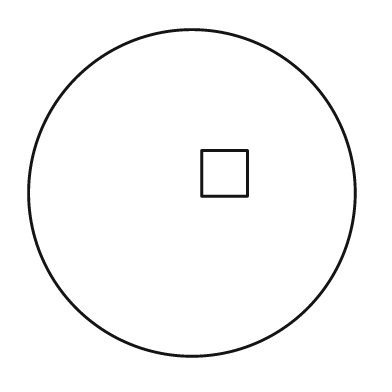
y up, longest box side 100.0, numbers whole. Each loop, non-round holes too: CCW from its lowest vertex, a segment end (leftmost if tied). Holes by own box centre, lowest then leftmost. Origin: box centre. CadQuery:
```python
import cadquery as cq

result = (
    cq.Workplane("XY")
    .moveTo(0.0, 0.0)
    .circle(50.0)
    .moveTo(3.0, -1.0)
    .lineTo(17.0, -1.0)
    .lineTo(17.0, 13.0)
    .lineTo(3.0, 13.0)
    .close()
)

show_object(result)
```